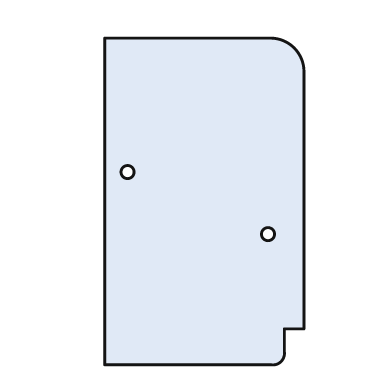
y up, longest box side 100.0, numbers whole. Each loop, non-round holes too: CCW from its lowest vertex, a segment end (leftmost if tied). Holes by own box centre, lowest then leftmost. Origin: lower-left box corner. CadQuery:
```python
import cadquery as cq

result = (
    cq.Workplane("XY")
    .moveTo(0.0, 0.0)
    .lineTo(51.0, 0.0)
    .threePointArc((54.0, 1.0), (55.0, 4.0))
    .lineTo(55.0, 11.0)
    .lineTo(61.0, 11.0)
    .lineTo(61.0, 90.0)
    .threePointArc((58.0, 97.0), (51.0, 100.0))
    .lineTo(0.0, 100.0)
    .close()
    .moveTo(50.0, 40.0)
    .circle(2.0)
    .moveTo(7.0, 59.0)
    .circle(2.0)
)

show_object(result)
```